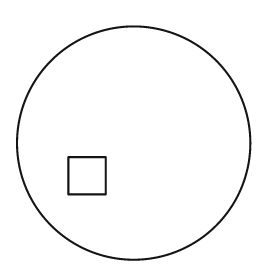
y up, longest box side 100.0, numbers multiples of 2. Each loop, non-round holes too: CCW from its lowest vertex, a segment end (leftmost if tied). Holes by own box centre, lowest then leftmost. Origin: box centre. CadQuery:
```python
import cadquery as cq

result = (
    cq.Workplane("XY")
    .moveTo(0.0, 0.0)
    .circle(50.0)
    .moveTo(-28.0, -22.0)
    .lineTo(-12.0, -22.0)
    .lineTo(-12.0, -6.0)
    .lineTo(-28.0, -6.0)
    .close()
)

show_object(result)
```